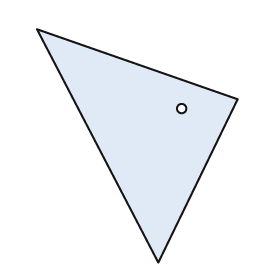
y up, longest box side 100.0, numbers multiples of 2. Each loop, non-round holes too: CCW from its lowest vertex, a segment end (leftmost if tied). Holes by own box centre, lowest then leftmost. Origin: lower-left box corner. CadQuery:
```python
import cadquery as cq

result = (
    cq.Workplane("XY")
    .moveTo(52.0, 0.0)
    .lineTo(86.0, 70.0)
    .lineTo(0.0, 100.0)
    .close()
    .moveTo(62.0, 66.0)
    .circle(2.0)
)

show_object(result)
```